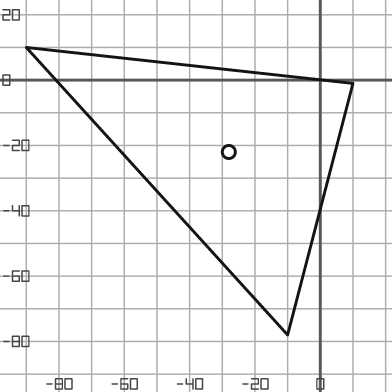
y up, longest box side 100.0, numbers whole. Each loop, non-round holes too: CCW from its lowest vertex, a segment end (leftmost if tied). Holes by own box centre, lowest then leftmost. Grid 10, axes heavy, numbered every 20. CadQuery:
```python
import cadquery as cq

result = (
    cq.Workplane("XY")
    .moveTo(-10.0, -78.0)
    .lineTo(10.0, -1.0)
    .lineTo(-90.0, 10.0)
    .close()
    .moveTo(-28.0, -22.0)
    .circle(2.0)
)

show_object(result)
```